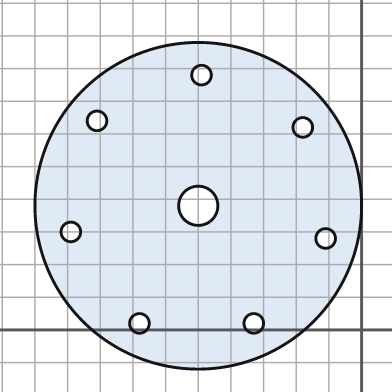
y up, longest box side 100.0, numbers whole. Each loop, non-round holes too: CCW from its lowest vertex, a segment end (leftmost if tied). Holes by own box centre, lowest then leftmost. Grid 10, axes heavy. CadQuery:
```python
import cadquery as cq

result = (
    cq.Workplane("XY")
    .moveTo(-50.0, 38.0)
    .circle(50.0)
    .moveTo(-68.0, 2.0)
    .circle(3.0)
    .moveTo(-33.0, 2.0)
    .circle(3.0)
    .moveTo(-11.0, 28.0)
    .circle(3.0)
    .moveTo(-89.0, 30.0)
    .circle(3.0)
    .moveTo(-50.0, 38.0)
    .circle(6.0)
    .moveTo(-18.0, 62.0)
    .circle(3.0)
    .moveTo(-81.0, 64.0)
    .circle(3.0)
    .moveTo(-49.0, 78.0)
    .circle(3.0)
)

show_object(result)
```